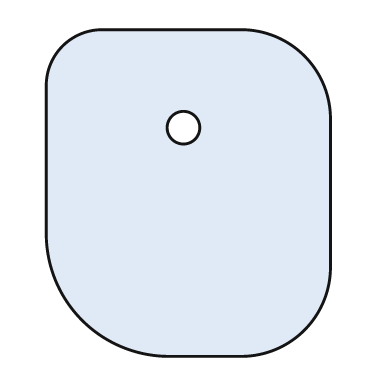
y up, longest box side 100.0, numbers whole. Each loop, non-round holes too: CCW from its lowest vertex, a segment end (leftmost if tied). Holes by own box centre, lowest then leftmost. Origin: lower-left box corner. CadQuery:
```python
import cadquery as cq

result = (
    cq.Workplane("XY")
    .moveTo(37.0, 0.0)
    .lineTo(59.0, 0.0)
    .threePointArc((79.0, 8.0), (87.0, 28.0))
    .lineTo(87.0, 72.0)
    .threePointArc((79.0, 92.0), (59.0, 100.0))
    .lineTo(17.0, 100.0)
    .threePointArc((5.0, 95.0), (0.0, 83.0))
    .lineTo(0.0, 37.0)
    .threePointArc((11.0, 11.0), (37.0, 0.0))
    .close()
    .moveTo(42.0, 70.0)
    .circle(5.0)
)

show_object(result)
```